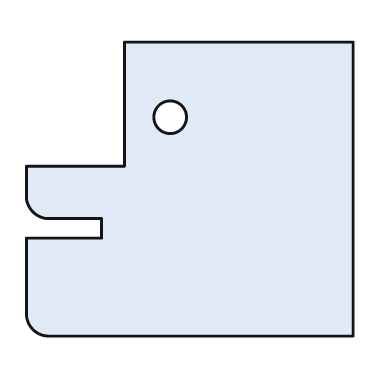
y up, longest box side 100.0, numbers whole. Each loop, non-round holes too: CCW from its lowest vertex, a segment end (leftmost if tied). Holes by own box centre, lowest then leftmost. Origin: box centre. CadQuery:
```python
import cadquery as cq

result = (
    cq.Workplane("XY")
    .moveTo(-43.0, -45.0)
    .lineTo(50.0, -45.0)
    .lineTo(50.0, 45.0)
    .lineTo(-20.0, 45.0)
    .lineTo(-20.0, 7.0)
    .lineTo(-50.0, 7.0)
    .lineTo(-50.0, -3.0)
    .threePointArc((-48.0, -7.0), (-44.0, -9.0))
    .lineTo(-27.0, -9.0)
    .lineTo(-27.0, -15.0)
    .lineTo(-50.0, -15.0)
    .lineTo(-50.0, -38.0)
    .threePointArc((-48.0, -43.0), (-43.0, -45.0))
    .close()
    .moveTo(-6.0, 22.0)
    .circle(5.0)
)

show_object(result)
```